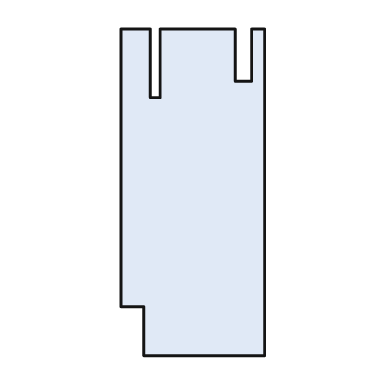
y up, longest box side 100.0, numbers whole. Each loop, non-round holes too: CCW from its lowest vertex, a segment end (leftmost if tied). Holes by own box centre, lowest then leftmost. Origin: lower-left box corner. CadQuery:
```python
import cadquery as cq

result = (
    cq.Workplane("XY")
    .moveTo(7.0, 0.0)
    .lineTo(44.0, 0.0)
    .lineTo(44.0, 100.0)
    .lineTo(40.0, 100.0)
    .lineTo(40.0, 84.0)
    .lineTo(35.0, 84.0)
    .lineTo(35.0, 100.0)
    .lineTo(12.0, 100.0)
    .lineTo(12.0, 79.0)
    .lineTo(9.0, 79.0)
    .lineTo(9.0, 100.0)
    .lineTo(0.0, 100.0)
    .lineTo(0.0, 15.0)
    .lineTo(7.0, 15.0)
    .close()
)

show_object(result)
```